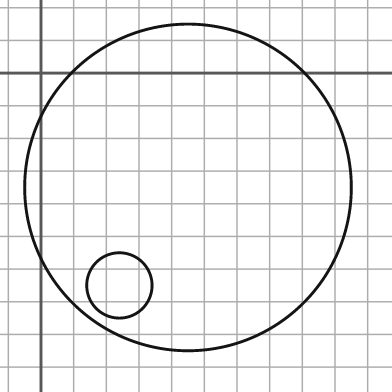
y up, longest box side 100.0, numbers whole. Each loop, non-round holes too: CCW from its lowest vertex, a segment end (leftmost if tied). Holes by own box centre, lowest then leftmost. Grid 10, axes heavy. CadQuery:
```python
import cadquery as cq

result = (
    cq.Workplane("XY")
    .moveTo(45.0, -35.0)
    .circle(50.0)
    .moveTo(24.0, -65.0)
    .circle(10.0)
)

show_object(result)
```